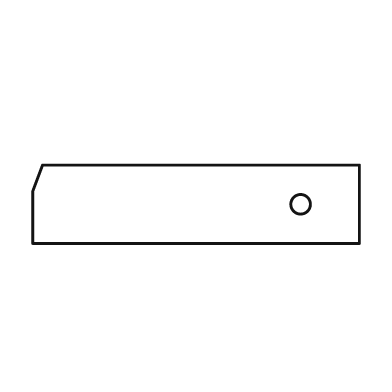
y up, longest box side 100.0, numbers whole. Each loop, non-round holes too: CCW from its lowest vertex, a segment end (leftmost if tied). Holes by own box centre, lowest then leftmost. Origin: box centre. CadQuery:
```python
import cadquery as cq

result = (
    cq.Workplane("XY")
    .moveTo(-50.0, -12.0)
    .lineTo(50.0, -12.0)
    .lineTo(50.0, 12.0)
    .lineTo(-47.0, 12.0)
    .lineTo(-50.0, 4.0)
    .close()
    .moveTo(32.0, 0.0)
    .circle(3.0)
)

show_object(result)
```